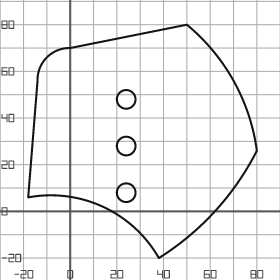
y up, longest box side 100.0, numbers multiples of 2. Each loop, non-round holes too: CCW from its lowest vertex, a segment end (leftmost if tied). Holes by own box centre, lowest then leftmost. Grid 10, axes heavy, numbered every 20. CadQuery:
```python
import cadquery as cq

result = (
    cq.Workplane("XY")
    .moveTo(38.0, -20.0)
    .threePointArc((62.0, 0.0), (80.0, 26.0))
    .threePointArc((70.0, 56.0), (50.0, 80.0))
    .lineTo(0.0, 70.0)
    .threePointArc((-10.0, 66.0), (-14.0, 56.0))
    .lineTo(-18.0, 6.0)
    .threePointArc((14.0, 2.0), (38.0, -20.0))
    .close()
    .moveTo(24.0, 8.0)
    .circle(4.0)
    .moveTo(24.0, 28.0)
    .circle(4.0)
    .moveTo(24.0, 48.0)
    .circle(4.0)
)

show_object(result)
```